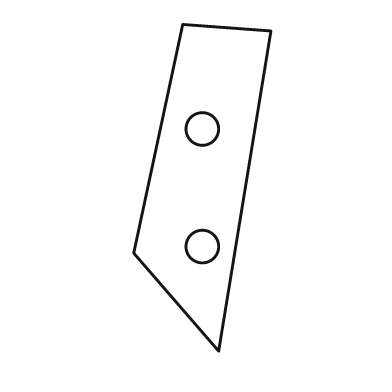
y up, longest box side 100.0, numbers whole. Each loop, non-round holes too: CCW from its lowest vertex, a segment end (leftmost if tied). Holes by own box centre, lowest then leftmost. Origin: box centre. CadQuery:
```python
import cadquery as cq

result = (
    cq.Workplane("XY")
    .moveTo(5.0, -50.0)
    .lineTo(21.0, 48.0)
    .lineTo(-6.0, 50.0)
    .lineTo(-21.0, -20.0)
    .close()
    .moveTo(0.0, -18.0)
    .circle(5.0)
    .moveTo(0.0, 18.0)
    .circle(5.0)
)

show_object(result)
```